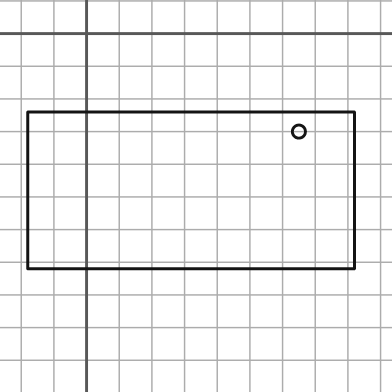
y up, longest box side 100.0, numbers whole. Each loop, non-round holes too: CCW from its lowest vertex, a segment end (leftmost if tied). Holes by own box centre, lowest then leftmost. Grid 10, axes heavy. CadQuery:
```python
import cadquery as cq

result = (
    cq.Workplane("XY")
    .moveTo(-18.0, -72.0)
    .lineTo(82.0, -72.0)
    .lineTo(82.0, -24.0)
    .lineTo(-18.0, -24.0)
    .close()
    .moveTo(65.0, -30.0)
    .circle(2.0)
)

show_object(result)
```